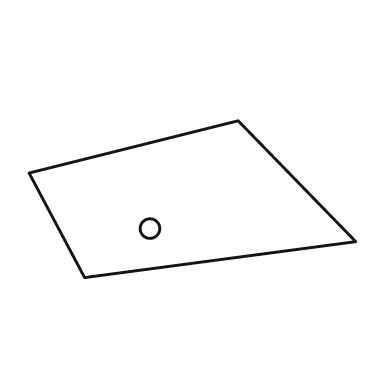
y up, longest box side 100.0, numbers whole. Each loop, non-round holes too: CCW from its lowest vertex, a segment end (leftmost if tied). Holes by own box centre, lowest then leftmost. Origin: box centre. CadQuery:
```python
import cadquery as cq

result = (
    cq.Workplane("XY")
    .moveTo(-33.0, -24.0)
    .lineTo(50.0, -13.0)
    .lineTo(14.0, 24.0)
    .lineTo(-50.0, 8.0)
    .close()
    .moveTo(-13.0, -9.0)
    .circle(3.0)
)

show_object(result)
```